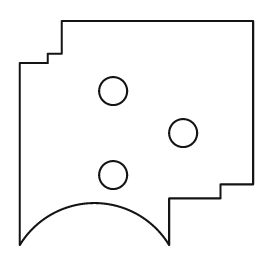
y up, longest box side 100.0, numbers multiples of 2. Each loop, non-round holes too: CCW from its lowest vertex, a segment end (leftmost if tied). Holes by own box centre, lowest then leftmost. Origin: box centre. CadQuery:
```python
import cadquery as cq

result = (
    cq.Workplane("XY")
    .moveTo(-50.0, -48.0)
    .threePointArc((-18.0, -30.0), (14.0, -48.0))
    .lineTo(14.0, -28.0)
    .lineTo(36.0, -28.0)
    .lineTo(36.0, -22.0)
    .lineTo(50.0, -22.0)
    .lineTo(50.0, 48.0)
    .lineTo(-32.0, 48.0)
    .lineTo(-32.0, 34.0)
    .lineTo(-38.0, 34.0)
    .lineTo(-38.0, 30.0)
    .lineTo(-50.0, 30.0)
    .close()
    .moveTo(-10.0, -18.0)
    .circle(6.0)
    .moveTo(20.0, 0.0)
    .circle(6.0)
    .moveTo(-10.0, 18.0)
    .circle(6.0)
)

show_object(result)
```